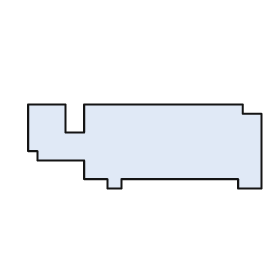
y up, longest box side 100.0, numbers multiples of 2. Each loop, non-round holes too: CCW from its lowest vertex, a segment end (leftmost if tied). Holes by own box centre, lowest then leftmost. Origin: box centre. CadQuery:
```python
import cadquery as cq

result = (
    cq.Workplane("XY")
    .moveTo(-16.0, -18.0)
    .lineTo(-10.0, -18.0)
    .lineTo(-10.0, -14.0)
    .lineTo(40.0, -14.0)
    .lineTo(40.0, -18.0)
    .lineTo(50.0, -18.0)
    .lineTo(50.0, 14.0)
    .lineTo(42.0, 14.0)
    .lineTo(42.0, 18.0)
    .lineTo(-26.0, 18.0)
    .lineTo(-26.0, 6.0)
    .lineTo(-34.0, 6.0)
    .lineTo(-34.0, 18.0)
    .lineTo(-50.0, 18.0)
    .lineTo(-50.0, -2.0)
    .lineTo(-46.0, -2.0)
    .lineTo(-46.0, -6.0)
    .lineTo(-26.0, -6.0)
    .lineTo(-26.0, -14.0)
    .lineTo(-16.0, -14.0)
    .close()
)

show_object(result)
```